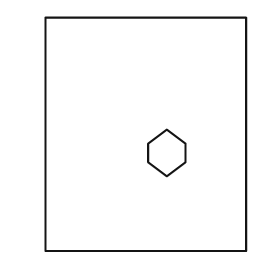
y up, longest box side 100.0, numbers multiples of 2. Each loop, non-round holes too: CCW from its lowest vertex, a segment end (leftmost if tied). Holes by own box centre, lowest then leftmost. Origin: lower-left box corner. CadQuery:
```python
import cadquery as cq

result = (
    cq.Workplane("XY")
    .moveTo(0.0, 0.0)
    .lineTo(86.0, 0.0)
    .lineTo(86.0, 100.0)
    .lineTo(0.0, 100.0)
    .close()
    .moveTo(52.0, 32.0)
    .lineTo(60.0, 38.0)
    .lineTo(60.0, 46.0)
    .lineTo(52.0, 52.0)
    .lineTo(44.0, 46.0)
    .lineTo(44.0, 38.0)
    .close()
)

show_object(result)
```